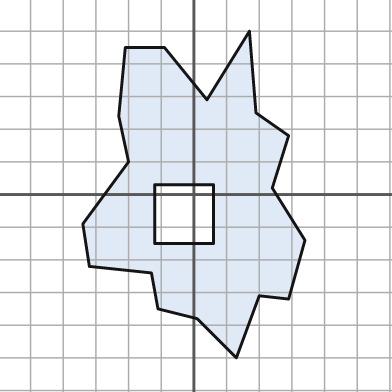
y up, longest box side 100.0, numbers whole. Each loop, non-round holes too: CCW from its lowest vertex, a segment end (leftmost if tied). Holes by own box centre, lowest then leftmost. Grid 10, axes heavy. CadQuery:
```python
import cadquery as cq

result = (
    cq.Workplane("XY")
    .moveTo(13.0, -50.0)
    .lineTo(20.0, -31.0)
    .lineTo(29.0, -32.0)
    .lineTo(34.0, -14.0)
    .lineTo(24.0, 2.0)
    .lineTo(29.0, 18.0)
    .lineTo(19.0, 25.0)
    .lineTo(17.0, 50.0)
    .lineTo(4.0, 29.0)
    .lineTo(-9.0, 45.0)
    .lineTo(-21.0, 45.0)
    .lineTo(-23.0, 24.0)
    .lineTo(-20.0, 10.0)
    .lineTo(-34.0, -9.0)
    .lineTo(-32.0, -22.0)
    .lineTo(-13.0, -24.0)
    .lineTo(-11.0, -35.0)
    .lineTo(1.0, -38.0)
    .close()
    .moveTo(-12.0, -15.0)
    .lineTo(6.0, -15.0)
    .lineTo(6.0, 3.0)
    .lineTo(-12.0, 3.0)
    .close()
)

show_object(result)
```